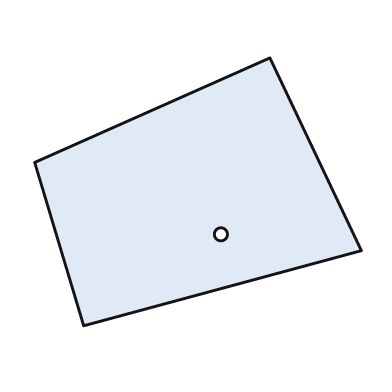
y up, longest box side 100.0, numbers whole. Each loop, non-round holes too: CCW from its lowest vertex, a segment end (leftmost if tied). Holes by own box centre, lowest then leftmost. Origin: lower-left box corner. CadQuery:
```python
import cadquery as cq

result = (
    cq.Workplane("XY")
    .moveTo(15.0, 0.0)
    .lineTo(100.0, 23.0)
    .lineTo(72.0, 82.0)
    .lineTo(0.0, 50.0)
    .close()
    .moveTo(57.0, 28.0)
    .circle(2.0)
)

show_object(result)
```